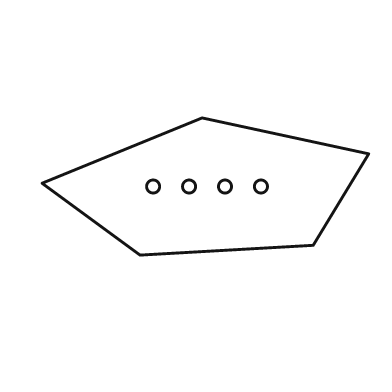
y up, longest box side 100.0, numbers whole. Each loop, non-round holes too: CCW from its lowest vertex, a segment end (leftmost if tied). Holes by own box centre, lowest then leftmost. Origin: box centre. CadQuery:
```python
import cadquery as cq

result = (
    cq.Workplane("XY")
    .moveTo(-20.0, -21.0)
    .lineTo(33.0, -18.0)
    .lineTo(50.0, 10.0)
    .lineTo(-1.0, 21.0)
    .lineTo(-50.0, 1.0)
    .close()
    .moveTo(-16.0, 0.0)
    .circle(2.0)
    .moveTo(-5.0, 0.0)
    .circle(2.0)
    .moveTo(6.0, 0.0)
    .circle(2.0)
    .moveTo(17.0, 0.0)
    .circle(2.0)
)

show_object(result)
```